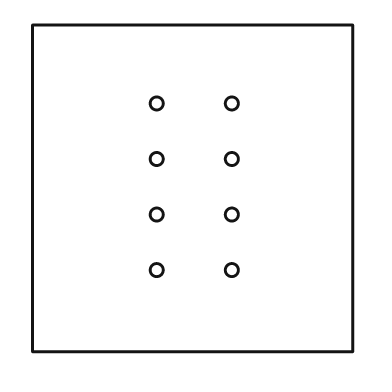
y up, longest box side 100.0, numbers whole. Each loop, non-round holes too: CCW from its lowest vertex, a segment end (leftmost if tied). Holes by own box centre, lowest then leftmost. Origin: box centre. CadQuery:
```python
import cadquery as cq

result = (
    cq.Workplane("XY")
    .moveTo(-49.0, -50.0)
    .lineTo(49.0, -50.0)
    .lineTo(49.0, 50.0)
    .lineTo(-49.0, 50.0)
    .close()
    .moveTo(-11.0, -25.0)
    .circle(2.0)
    .moveTo(12.0, -25.0)
    .circle(2.0)
    .moveTo(-11.0, -8.0)
    .circle(2.0)
    .moveTo(12.0, -8.0)
    .circle(2.0)
    .moveTo(-11.0, 9.0)
    .circle(2.0)
    .moveTo(12.0, 9.0)
    .circle(2.0)
    .moveTo(-11.0, 26.0)
    .circle(2.0)
    .moveTo(12.0, 26.0)
    .circle(2.0)
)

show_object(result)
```